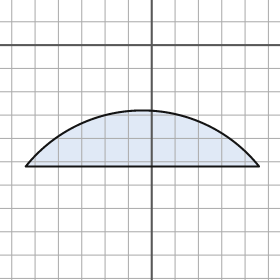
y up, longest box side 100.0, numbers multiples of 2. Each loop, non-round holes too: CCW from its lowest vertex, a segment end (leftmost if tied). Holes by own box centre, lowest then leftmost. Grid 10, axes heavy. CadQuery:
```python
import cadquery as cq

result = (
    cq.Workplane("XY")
    .moveTo(-54.0, -52.0)
    .lineTo(46.0, -52.0)
    .threePointArc((-4.0, -28.0), (-54.0, -52.0))
    .close()
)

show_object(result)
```